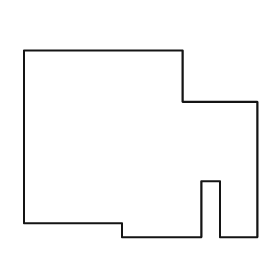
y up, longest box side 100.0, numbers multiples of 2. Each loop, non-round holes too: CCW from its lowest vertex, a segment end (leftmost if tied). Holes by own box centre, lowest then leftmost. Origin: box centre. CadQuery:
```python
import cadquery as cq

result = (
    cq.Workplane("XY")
    .moveTo(-8.0, -40.0)
    .lineTo(26.0, -40.0)
    .lineTo(26.0, -16.0)
    .lineTo(34.0, -16.0)
    .lineTo(34.0, -40.0)
    .lineTo(50.0, -40.0)
    .lineTo(50.0, 18.0)
    .lineTo(18.0, 18.0)
    .lineTo(18.0, 40.0)
    .lineTo(-50.0, 40.0)
    .lineTo(-50.0, -34.0)
    .lineTo(-8.0, -34.0)
    .close()
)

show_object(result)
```